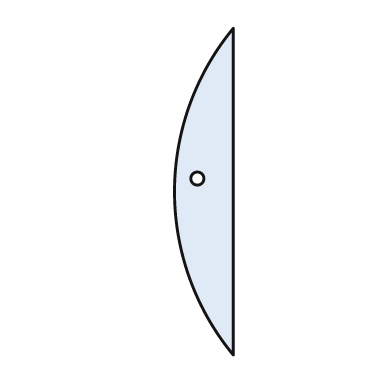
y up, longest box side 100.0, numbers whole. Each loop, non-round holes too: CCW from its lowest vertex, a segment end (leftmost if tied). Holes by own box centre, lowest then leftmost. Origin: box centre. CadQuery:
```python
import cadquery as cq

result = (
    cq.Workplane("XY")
    .moveTo(9.0, -50.0)
    .lineTo(9.0, 50.0)
    .threePointArc((-9.0, 0.0), (9.0, -50.0))
    .close()
    .moveTo(-2.0, 4.0)
    .circle(2.0)
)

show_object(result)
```